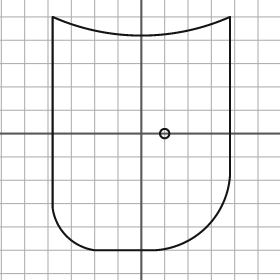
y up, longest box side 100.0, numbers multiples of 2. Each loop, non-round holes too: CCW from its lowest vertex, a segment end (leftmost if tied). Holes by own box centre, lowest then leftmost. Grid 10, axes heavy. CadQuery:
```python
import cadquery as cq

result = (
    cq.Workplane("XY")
    .moveTo(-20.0, -50.0)
    .lineTo(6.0, -50.0)
    .threePointArc((28.0, -40.0), (38.0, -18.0))
    .lineTo(38.0, 50.0)
    .threePointArc((0.0, 42.0), (-38.0, 50.0))
    .lineTo(-38.0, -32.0)
    .threePointArc((-32.0, -44.0), (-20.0, -50.0))
    .close()
    .moveTo(10.0, 0.0)
    .circle(2.0)
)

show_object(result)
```